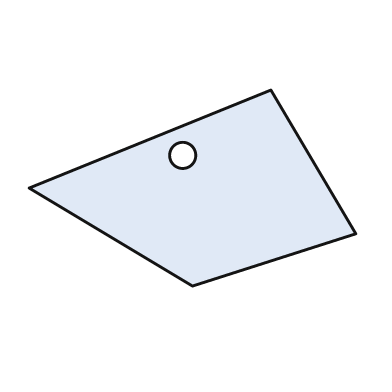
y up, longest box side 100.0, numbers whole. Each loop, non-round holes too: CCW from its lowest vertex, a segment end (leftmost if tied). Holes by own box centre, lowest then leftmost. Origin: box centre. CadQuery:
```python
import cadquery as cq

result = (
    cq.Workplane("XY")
    .moveTo(0.0, -30.0)
    .lineTo(50.0, -14.0)
    .lineTo(24.0, 30.0)
    .lineTo(-50.0, 0.0)
    .close()
    .moveTo(-3.0, 10.0)
    .circle(4.0)
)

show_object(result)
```